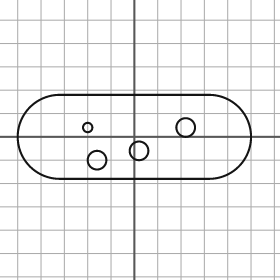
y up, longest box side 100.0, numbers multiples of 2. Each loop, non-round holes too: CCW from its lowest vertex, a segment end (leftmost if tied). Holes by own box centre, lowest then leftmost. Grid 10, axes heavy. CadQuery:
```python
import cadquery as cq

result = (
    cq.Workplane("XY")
    .moveTo(-32.0, -18.0)
    .lineTo(32.0, -18.0)
    .threePointArc((50.0, 0.0), (32.0, 18.0))
    .lineTo(-32.0, 18.0)
    .threePointArc((-50.0, 0.0), (-32.0, -18.0))
    .close()
    .moveTo(-16.0, -10.0)
    .circle(4.0)
    .moveTo(2.0, -6.0)
    .circle(4.0)
    .moveTo(-20.0, 4.0)
    .circle(2.0)
    .moveTo(22.0, 4.0)
    .circle(4.0)
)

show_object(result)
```